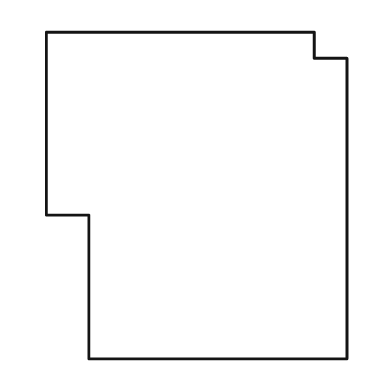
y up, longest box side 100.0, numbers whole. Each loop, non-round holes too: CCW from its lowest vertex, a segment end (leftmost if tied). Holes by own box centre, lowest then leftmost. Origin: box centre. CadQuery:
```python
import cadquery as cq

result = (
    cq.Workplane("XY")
    .moveTo(-33.0, -50.0)
    .lineTo(46.0, -50.0)
    .lineTo(46.0, 42.0)
    .lineTo(36.0, 42.0)
    .lineTo(36.0, 50.0)
    .lineTo(-46.0, 50.0)
    .lineTo(-46.0, -6.0)
    .lineTo(-33.0, -6.0)
    .close()
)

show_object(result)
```